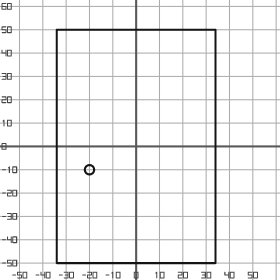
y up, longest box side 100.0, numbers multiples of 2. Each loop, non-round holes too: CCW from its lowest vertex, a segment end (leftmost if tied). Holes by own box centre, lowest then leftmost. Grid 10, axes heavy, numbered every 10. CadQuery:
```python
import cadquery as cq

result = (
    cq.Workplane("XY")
    .moveTo(-34.0, -50.0)
    .lineTo(34.0, -50.0)
    .lineTo(34.0, 50.0)
    .lineTo(-34.0, 50.0)
    .close()
    .moveTo(-20.0, -10.0)
    .circle(2.0)
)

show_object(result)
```